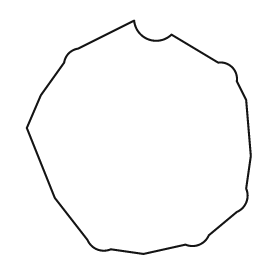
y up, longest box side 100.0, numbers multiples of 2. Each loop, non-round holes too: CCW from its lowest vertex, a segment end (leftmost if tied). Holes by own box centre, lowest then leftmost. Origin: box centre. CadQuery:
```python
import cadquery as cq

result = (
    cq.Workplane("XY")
    .moveTo(2.0, -50.0)
    .lineTo(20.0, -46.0)
    .threePointArc((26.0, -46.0), (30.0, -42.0))
    .lineTo(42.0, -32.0)
    .threePointArc((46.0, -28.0), (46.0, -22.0))
    .lineTo(48.0, -8.0)
    .lineTo(46.0, 16.0)
    .lineTo(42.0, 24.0)
    .threePointArc((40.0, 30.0), (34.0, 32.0))
    .lineTo(14.0, 44.0)
    .threePointArc((4.0, 42.0), (-2.0, 50.0))
    .lineTo(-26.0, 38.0)
    .threePointArc((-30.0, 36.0), (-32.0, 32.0))
    .lineTo(-42.0, 18.0)
    .lineTo(-48.0, 4.0)
    .lineTo(-36.0, -26.0)
    .lineTo(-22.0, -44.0)
    .threePointArc((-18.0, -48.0), (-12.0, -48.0))
    .close()
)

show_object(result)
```